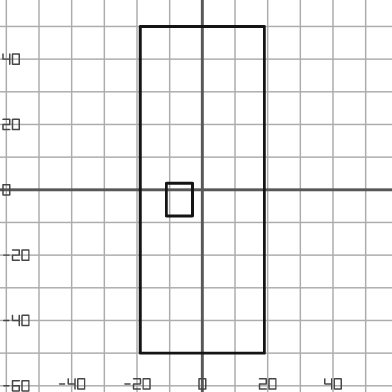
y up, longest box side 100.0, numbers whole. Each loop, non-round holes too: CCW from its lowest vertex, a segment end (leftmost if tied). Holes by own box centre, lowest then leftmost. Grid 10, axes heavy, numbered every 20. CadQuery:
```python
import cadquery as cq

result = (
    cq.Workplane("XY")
    .moveTo(-19.0, -50.0)
    .lineTo(19.0, -50.0)
    .lineTo(19.0, 50.0)
    .lineTo(-19.0, 50.0)
    .close()
    .moveTo(-11.0, -8.0)
    .lineTo(-3.0, -8.0)
    .lineTo(-3.0, 2.0)
    .lineTo(-11.0, 2.0)
    .close()
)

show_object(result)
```